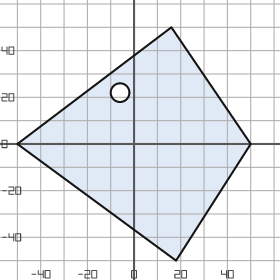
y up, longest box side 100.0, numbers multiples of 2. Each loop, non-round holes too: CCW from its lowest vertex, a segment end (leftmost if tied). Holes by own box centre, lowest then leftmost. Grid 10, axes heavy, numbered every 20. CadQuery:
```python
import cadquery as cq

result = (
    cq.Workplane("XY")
    .moveTo(18.0, -50.0)
    .lineTo(50.0, 0.0)
    .lineTo(16.0, 50.0)
    .lineTo(-50.0, 0.0)
    .close()
    .moveTo(-6.0, 22.0)
    .circle(4.0)
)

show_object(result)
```